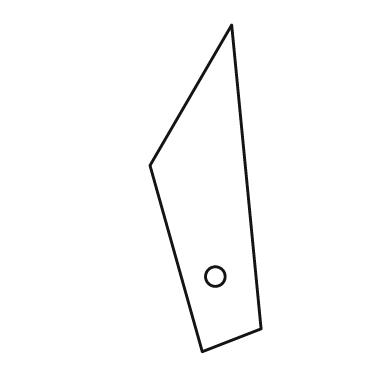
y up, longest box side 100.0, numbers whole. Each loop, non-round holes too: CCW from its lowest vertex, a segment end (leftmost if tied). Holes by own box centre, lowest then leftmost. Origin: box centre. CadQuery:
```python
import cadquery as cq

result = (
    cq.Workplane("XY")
    .moveTo(-1.0, -50.0)
    .lineTo(17.0, -43.0)
    .lineTo(8.0, 50.0)
    .lineTo(-17.0, 7.0)
    .close()
    .moveTo(3.0, -27.0)
    .circle(3.0)
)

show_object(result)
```